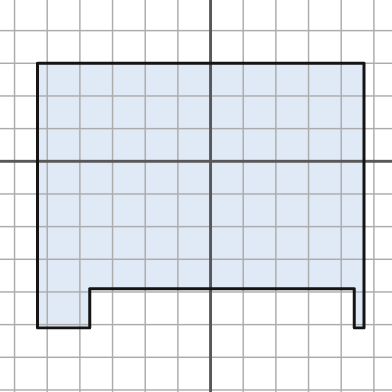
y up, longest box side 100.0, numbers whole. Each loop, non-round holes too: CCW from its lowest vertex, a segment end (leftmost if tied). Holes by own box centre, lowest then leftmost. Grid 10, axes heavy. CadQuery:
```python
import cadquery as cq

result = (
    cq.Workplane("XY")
    .moveTo(-53.0, -51.0)
    .lineTo(-37.0, -51.0)
    .lineTo(-37.0, -39.0)
    .lineTo(44.0, -39.0)
    .lineTo(44.0, -51.0)
    .lineTo(47.0, -51.0)
    .lineTo(47.0, 30.0)
    .lineTo(-53.0, 30.0)
    .close()
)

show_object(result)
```